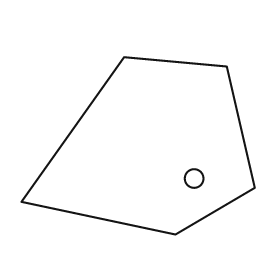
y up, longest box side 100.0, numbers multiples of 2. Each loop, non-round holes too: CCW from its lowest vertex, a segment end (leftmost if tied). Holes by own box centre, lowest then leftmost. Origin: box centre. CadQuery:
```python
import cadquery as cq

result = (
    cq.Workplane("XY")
    .moveTo(16.0, -38.0)
    .lineTo(50.0, -18.0)
    .lineTo(38.0, 34.0)
    .lineTo(-6.0, 38.0)
    .lineTo(-50.0, -24.0)
    .close()
    .moveTo(24.0, -14.0)
    .circle(4.0)
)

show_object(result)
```